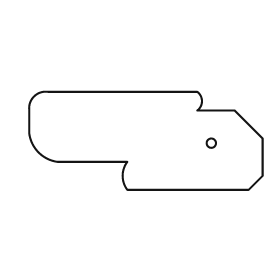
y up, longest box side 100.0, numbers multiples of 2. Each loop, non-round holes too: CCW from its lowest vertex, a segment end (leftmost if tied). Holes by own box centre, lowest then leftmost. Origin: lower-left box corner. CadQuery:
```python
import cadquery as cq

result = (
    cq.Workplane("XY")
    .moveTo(42.0, 0.0)
    .lineTo(94.0, 0.0)
    .lineTo(100.0, 6.0)
    .lineTo(100.0, 22.0)
    .lineTo(88.0, 34.0)
    .lineTo(72.0, 34.0)
    .threePointArc((74.0, 38.0), (72.0, 42.0))
    .lineTo(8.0, 42.0)
    .threePointArc((2.0, 40.0), (0.0, 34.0))
    .lineTo(0.0, 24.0)
    .threePointArc((4.0, 16.0), (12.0, 12.0))
    .lineTo(42.0, 12.0)
    .threePointArc((40.0, 6.0), (42.0, 0.0))
    .close()
    .moveTo(78.0, 20.0)
    .circle(2.0)
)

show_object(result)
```